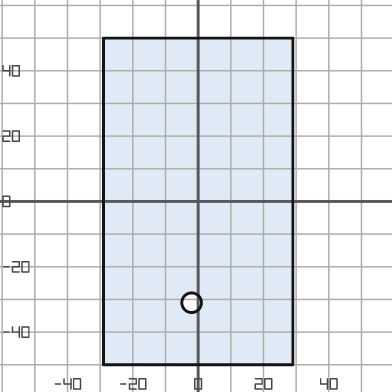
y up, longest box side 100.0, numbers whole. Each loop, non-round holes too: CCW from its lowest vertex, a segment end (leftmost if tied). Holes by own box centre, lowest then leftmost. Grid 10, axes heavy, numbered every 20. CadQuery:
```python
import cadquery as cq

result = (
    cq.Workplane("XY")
    .moveTo(-29.0, -50.0)
    .lineTo(29.0, -50.0)
    .lineTo(29.0, 50.0)
    .lineTo(-29.0, 50.0)
    .close()
    .moveTo(-2.0, -31.0)
    .circle(3.0)
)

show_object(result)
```